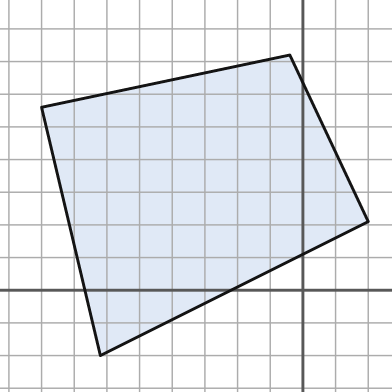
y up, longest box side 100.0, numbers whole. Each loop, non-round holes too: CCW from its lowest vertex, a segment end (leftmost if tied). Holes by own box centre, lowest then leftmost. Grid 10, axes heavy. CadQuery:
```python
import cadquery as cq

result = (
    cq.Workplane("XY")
    .moveTo(-62.0, -20.0)
    .lineTo(20.0, 21.0)
    .lineTo(-4.0, 72.0)
    .lineTo(-80.0, 56.0)
    .close()
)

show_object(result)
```